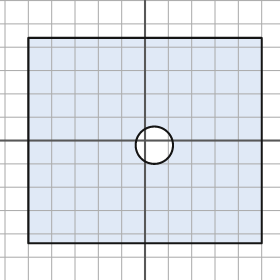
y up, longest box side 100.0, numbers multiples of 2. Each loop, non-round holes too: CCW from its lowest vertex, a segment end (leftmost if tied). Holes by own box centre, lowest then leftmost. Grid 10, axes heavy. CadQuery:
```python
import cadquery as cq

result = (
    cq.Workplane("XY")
    .moveTo(-50.0, -44.0)
    .lineTo(50.0, -44.0)
    .lineTo(50.0, 44.0)
    .lineTo(-50.0, 44.0)
    .close()
    .moveTo(4.0, -2.0)
    .circle(8.0)
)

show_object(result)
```